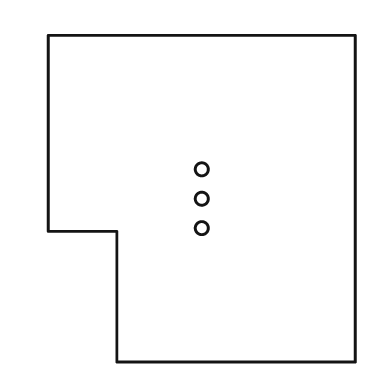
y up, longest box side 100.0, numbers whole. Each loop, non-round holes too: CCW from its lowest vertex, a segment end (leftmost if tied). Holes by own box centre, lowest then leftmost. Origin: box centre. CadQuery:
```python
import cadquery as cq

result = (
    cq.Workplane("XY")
    .moveTo(-26.0, -50.0)
    .lineTo(47.0, -50.0)
    .lineTo(47.0, 50.0)
    .lineTo(-47.0, 50.0)
    .lineTo(-47.0, -10.0)
    .lineTo(-26.0, -10.0)
    .close()
    .moveTo(0.0, -9.0)
    .circle(2.0)
    .moveTo(0.0, 0.0)
    .circle(2.0)
    .moveTo(0.0, 9.0)
    .circle(2.0)
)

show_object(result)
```